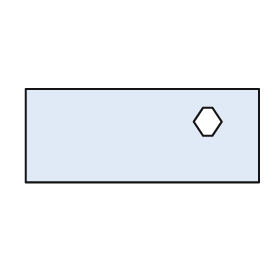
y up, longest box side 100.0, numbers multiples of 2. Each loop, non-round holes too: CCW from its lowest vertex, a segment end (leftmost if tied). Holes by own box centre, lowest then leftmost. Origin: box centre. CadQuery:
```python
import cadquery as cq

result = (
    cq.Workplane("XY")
    .moveTo(-50.0, -20.0)
    .lineTo(50.0, -20.0)
    .lineTo(50.0, 20.0)
    .lineTo(-50.0, 20.0)
    .close()
    .moveTo(26.0, 0.0)
    .lineTo(30.0, 0.0)
    .lineTo(34.0, 6.0)
    .lineTo(30.0, 12.0)
    .lineTo(26.0, 12.0)
    .lineTo(22.0, 6.0)
    .close()
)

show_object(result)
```